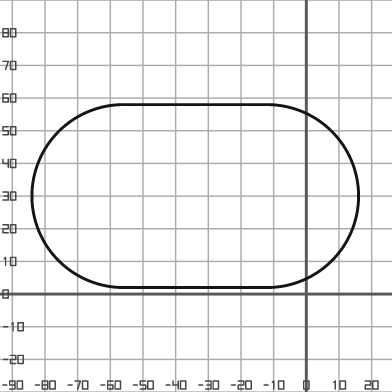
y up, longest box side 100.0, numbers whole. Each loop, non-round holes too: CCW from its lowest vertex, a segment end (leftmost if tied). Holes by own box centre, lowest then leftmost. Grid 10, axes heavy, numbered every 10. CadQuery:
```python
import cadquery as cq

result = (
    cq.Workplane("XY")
    .moveTo(-56.0, 2.0)
    .lineTo(-12.0, 2.0)
    .threePointArc((16.0, 30.0), (-12.0, 58.0))
    .lineTo(-56.0, 58.0)
    .threePointArc((-84.0, 30.0), (-56.0, 2.0))
    .close()
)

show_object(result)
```